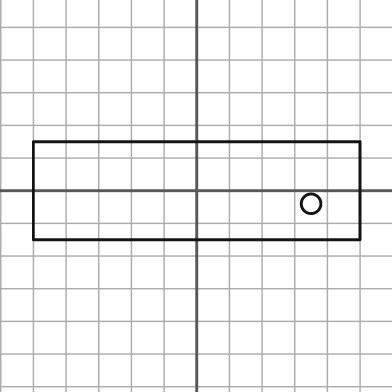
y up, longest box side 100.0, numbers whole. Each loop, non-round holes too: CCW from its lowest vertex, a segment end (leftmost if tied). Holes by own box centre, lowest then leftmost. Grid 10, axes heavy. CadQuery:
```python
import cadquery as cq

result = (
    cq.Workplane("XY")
    .moveTo(-50.0, -15.0)
    .lineTo(50.0, -15.0)
    .lineTo(50.0, 15.0)
    .lineTo(-50.0, 15.0)
    .close()
    .moveTo(35.0, -4.0)
    .circle(3.0)
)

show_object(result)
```